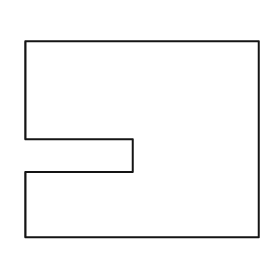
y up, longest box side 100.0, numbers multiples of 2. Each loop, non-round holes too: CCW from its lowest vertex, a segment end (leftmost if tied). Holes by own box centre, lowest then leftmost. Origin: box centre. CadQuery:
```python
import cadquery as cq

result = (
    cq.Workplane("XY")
    .moveTo(-50.0, -42.0)
    .lineTo(50.0, -42.0)
    .lineTo(50.0, 42.0)
    .lineTo(-50.0, 42.0)
    .lineTo(-50.0, 0.0)
    .lineTo(-4.0, 0.0)
    .lineTo(-4.0, -14.0)
    .lineTo(-50.0, -14.0)
    .close()
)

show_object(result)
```